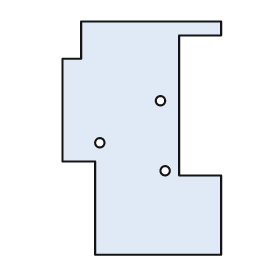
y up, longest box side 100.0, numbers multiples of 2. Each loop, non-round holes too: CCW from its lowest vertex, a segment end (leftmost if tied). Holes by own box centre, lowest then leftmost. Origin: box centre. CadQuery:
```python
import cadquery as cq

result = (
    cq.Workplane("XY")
    .moveTo(-20.0, -50.0)
    .lineTo(34.0, -50.0)
    .lineTo(34.0, -16.0)
    .lineTo(16.0, -16.0)
    .lineTo(16.0, 44.0)
    .lineTo(34.0, 44.0)
    .lineTo(34.0, 50.0)
    .lineTo(-26.0, 50.0)
    .lineTo(-26.0, 34.0)
    .lineTo(-34.0, 34.0)
    .lineTo(-34.0, -10.0)
    .lineTo(-20.0, -10.0)
    .close()
    .moveTo(10.0, -14.0)
    .circle(2.0)
    .moveTo(-18.0, -2.0)
    .circle(2.0)
    .moveTo(8.0, 16.0)
    .circle(2.0)
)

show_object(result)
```